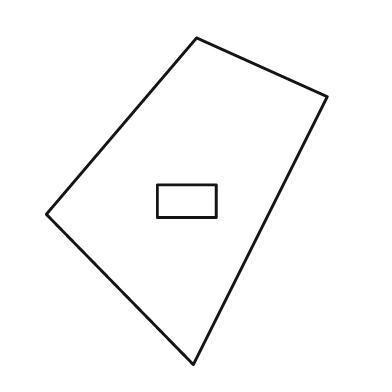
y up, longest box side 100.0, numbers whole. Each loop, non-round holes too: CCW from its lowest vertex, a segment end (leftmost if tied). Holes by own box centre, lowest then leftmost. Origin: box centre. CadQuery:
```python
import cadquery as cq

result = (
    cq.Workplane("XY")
    .moveTo(2.0, -50.0)
    .lineTo(43.0, 32.0)
    .lineTo(3.0, 50.0)
    .lineTo(-43.0, -4.0)
    .close()
    .moveTo(-9.0, -5.0)
    .lineTo(9.0, -5.0)
    .lineTo(9.0, 5.0)
    .lineTo(-9.0, 5.0)
    .close()
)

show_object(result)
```